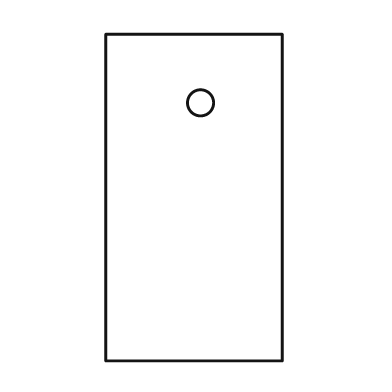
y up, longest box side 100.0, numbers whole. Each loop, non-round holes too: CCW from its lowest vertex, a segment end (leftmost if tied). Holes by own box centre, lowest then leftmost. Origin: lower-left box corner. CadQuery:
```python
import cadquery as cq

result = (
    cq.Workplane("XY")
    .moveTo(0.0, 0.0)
    .lineTo(54.0, 0.0)
    .lineTo(54.0, 100.0)
    .lineTo(0.0, 100.0)
    .close()
    .moveTo(29.0, 79.0)
    .circle(4.0)
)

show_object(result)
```